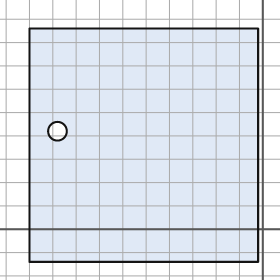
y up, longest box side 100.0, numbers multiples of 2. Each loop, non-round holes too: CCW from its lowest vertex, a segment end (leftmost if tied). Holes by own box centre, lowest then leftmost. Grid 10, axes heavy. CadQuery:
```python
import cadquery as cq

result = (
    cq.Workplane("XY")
    .moveTo(-100.0, -14.0)
    .lineTo(-2.0, -14.0)
    .lineTo(-2.0, 86.0)
    .lineTo(-100.0, 86.0)
    .close()
    .moveTo(-88.0, 42.0)
    .circle(4.0)
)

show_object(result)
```